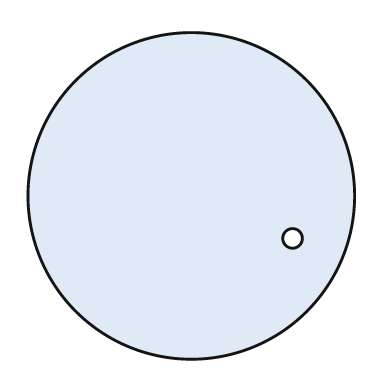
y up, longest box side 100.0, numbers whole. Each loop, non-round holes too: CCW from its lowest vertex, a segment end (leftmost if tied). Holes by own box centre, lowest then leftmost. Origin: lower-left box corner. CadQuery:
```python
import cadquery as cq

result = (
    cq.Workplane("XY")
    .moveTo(50.0, 50.0)
    .circle(50.0)
    .moveTo(81.0, 37.0)
    .circle(3.0)
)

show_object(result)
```